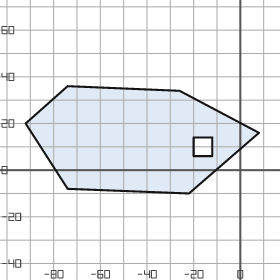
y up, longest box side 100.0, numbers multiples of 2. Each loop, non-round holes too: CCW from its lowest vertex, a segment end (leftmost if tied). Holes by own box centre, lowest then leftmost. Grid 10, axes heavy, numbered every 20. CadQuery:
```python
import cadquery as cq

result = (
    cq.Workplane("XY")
    .moveTo(-22.0, -10.0)
    .lineTo(8.0, 16.0)
    .lineTo(-26.0, 34.0)
    .lineTo(-74.0, 36.0)
    .lineTo(-92.0, 20.0)
    .lineTo(-74.0, -8.0)
    .close()
    .moveTo(-20.0, 6.0)
    .lineTo(-12.0, 6.0)
    .lineTo(-12.0, 14.0)
    .lineTo(-20.0, 14.0)
    .close()
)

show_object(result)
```